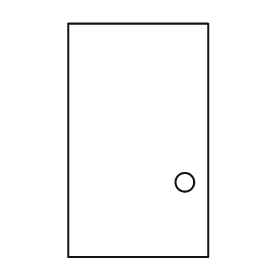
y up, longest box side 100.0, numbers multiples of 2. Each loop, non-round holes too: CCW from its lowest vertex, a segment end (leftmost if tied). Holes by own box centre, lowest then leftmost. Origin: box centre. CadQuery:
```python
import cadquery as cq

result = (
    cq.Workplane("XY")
    .moveTo(-30.0, -50.0)
    .lineTo(30.0, -50.0)
    .lineTo(30.0, 50.0)
    .lineTo(-30.0, 50.0)
    .close()
    .moveTo(20.0, -18.0)
    .circle(4.0)
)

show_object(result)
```